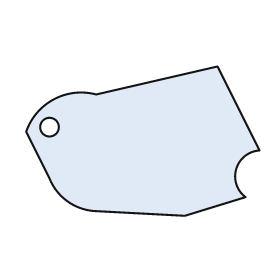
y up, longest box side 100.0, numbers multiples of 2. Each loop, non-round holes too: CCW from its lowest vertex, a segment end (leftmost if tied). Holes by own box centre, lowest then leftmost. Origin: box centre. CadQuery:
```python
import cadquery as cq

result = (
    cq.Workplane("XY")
    .moveTo(18.0, -32.0)
    .lineTo(44.0, -24.0)
    .threePointArc((40.0, -12.0), (50.0, -4.0))
    .lineTo(32.0, 32.0)
    .lineTo(-20.0, 20.0)
    .threePointArc((-38.0, 18.0), (-50.0, 4.0))
    .lineTo(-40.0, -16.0)
    .threePointArc((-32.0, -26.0), (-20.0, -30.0))
    .close()
    .moveTo(-40.0, 6.0)
    .circle(4.0)
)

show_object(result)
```